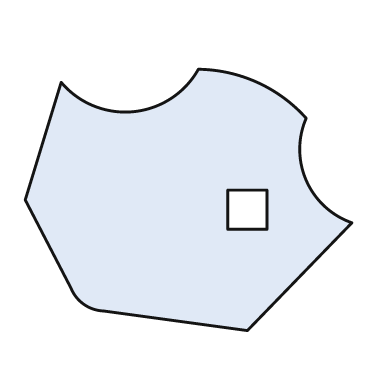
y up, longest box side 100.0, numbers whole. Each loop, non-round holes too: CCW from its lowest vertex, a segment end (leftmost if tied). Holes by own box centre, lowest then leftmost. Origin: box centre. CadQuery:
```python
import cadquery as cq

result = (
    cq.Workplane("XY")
    .moveTo(18.0, -40.0)
    .lineTo(50.0, -7.0)
    .threePointArc((36.0, 6.0), (36.0, 25.0))
    .threePointArc((21.0, 36.0), (3.0, 40.0))
    .threePointArc((-17.0, 27.0), (-39.0, 36.0))
    .lineTo(-50.0, 0.0)
    .lineTo(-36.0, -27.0)
    .threePointArc((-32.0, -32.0), (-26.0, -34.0))
    .close()
    .moveTo(12.0, -9.0)
    .lineTo(24.0, -9.0)
    .lineTo(24.0, 3.0)
    .lineTo(12.0, 3.0)
    .close()
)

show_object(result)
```